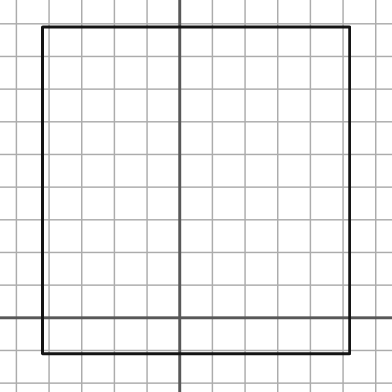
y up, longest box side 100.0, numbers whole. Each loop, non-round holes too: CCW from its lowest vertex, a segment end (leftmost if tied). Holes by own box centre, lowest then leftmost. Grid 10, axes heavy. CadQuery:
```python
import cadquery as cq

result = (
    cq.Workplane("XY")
    .moveTo(-42.0, -11.0)
    .lineTo(52.0, -11.0)
    .lineTo(52.0, 89.0)
    .lineTo(-42.0, 89.0)
    .close()
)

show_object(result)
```